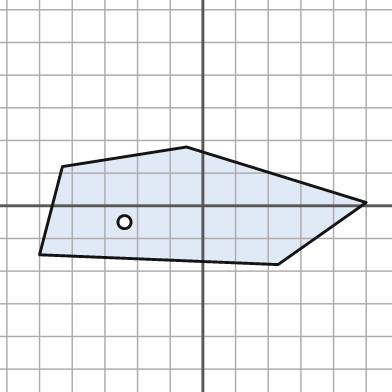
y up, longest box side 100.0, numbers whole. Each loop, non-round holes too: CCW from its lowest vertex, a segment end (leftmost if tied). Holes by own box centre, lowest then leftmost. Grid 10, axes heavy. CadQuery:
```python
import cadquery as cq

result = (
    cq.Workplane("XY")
    .moveTo(23.0, -18.0)
    .lineTo(50.0, 1.0)
    .lineTo(-5.0, 18.0)
    .lineTo(-43.0, 12.0)
    .lineTo(-50.0, -15.0)
    .close()
    .moveTo(-24.0, -5.0)
    .circle(2.0)
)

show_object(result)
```